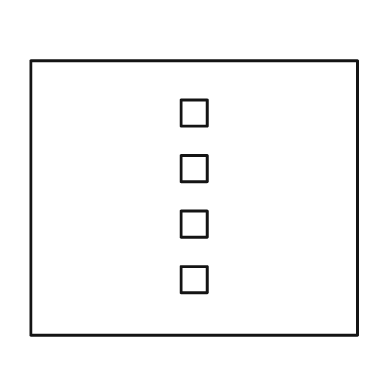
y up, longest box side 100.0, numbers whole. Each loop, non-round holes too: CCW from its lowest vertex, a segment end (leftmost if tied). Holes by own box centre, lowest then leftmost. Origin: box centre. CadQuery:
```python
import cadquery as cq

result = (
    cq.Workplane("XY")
    .moveTo(-50.0, -42.0)
    .lineTo(50.0, -42.0)
    .lineTo(50.0, 42.0)
    .lineTo(-50.0, 42.0)
    .close()
    .moveTo(-4.0, -29.0)
    .lineTo(4.0, -29.0)
    .lineTo(4.0, -21.0)
    .lineTo(-4.0, -21.0)
    .close()
    .moveTo(-4.0, -12.0)
    .lineTo(4.0, -12.0)
    .lineTo(4.0, -4.0)
    .lineTo(-4.0, -4.0)
    .close()
    .moveTo(-4.0, 5.0)
    .lineTo(4.0, 5.0)
    .lineTo(4.0, 13.0)
    .lineTo(-4.0, 13.0)
    .close()
    .moveTo(-4.0, 22.0)
    .lineTo(4.0, 22.0)
    .lineTo(4.0, 30.0)
    .lineTo(-4.0, 30.0)
    .close()
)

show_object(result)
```